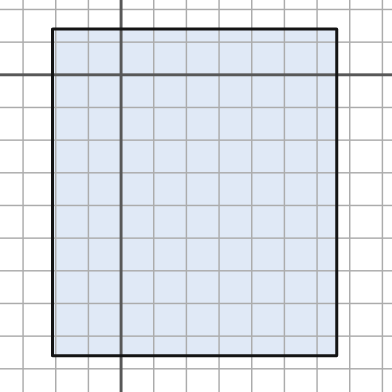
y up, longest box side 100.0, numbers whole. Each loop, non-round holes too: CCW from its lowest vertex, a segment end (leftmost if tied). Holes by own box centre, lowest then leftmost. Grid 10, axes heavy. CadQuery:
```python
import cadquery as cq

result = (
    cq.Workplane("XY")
    .moveTo(-21.0, -86.0)
    .lineTo(66.0, -86.0)
    .lineTo(66.0, 14.0)
    .lineTo(-21.0, 14.0)
    .close()
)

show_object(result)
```